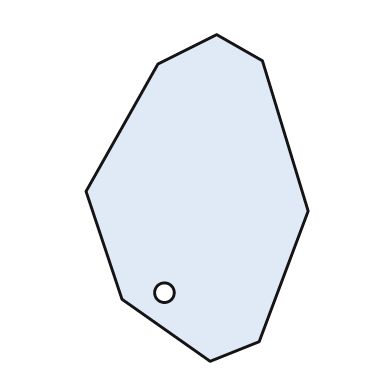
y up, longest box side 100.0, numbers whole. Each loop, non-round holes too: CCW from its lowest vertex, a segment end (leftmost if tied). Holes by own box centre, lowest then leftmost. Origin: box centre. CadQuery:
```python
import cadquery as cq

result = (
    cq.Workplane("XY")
    .moveTo(4.0, -50.0)
    .lineTo(19.0, -44.0)
    .lineTo(34.0, -4.0)
    .lineTo(20.0, 42.0)
    .lineTo(6.0, 50.0)
    .lineTo(-12.0, 41.0)
    .lineTo(-34.0, 2.0)
    .lineTo(-23.0, -31.0)
    .close()
    .moveTo(-10.0, -29.0)
    .circle(3.0)
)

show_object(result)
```